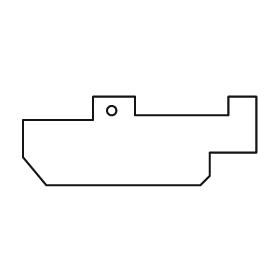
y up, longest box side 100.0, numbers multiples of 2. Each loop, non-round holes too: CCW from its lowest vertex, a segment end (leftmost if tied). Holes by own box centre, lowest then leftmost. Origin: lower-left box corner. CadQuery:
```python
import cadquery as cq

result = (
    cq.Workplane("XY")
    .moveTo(10.0, 0.0)
    .lineTo(76.0, 0.0)
    .lineTo(80.0, 4.0)
    .lineTo(80.0, 14.0)
    .lineTo(100.0, 14.0)
    .lineTo(100.0, 38.0)
    .lineTo(88.0, 38.0)
    .lineTo(88.0, 30.0)
    .lineTo(48.0, 30.0)
    .lineTo(48.0, 38.0)
    .lineTo(30.0, 38.0)
    .lineTo(30.0, 28.0)
    .lineTo(0.0, 28.0)
    .lineTo(0.0, 12.0)
    .close()
    .moveTo(38.0, 32.0)
    .circle(2.0)
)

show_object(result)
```